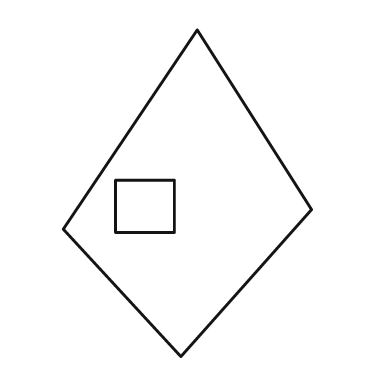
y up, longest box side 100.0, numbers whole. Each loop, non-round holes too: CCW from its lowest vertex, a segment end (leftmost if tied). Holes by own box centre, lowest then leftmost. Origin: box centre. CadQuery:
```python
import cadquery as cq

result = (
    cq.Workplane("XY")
    .moveTo(-2.0, -50.0)
    .lineTo(38.0, -5.0)
    .lineTo(3.0, 50.0)
    .lineTo(-38.0, -11.0)
    .close()
    .moveTo(-22.0, -12.0)
    .lineTo(-4.0, -12.0)
    .lineTo(-4.0, 4.0)
    .lineTo(-22.0, 4.0)
    .close()
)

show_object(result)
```